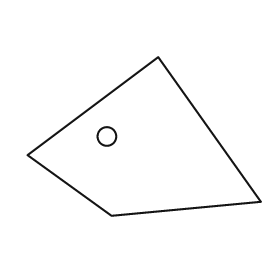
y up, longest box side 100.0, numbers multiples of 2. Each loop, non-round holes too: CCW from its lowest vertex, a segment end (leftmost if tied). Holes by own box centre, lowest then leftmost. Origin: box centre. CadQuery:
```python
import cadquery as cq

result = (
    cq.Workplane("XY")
    .moveTo(-14.0, -34.0)
    .lineTo(50.0, -28.0)
    .lineTo(6.0, 34.0)
    .lineTo(-50.0, -8.0)
    .close()
    .moveTo(-16.0, 0.0)
    .circle(4.0)
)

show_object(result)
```